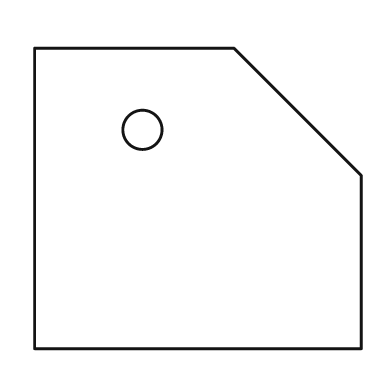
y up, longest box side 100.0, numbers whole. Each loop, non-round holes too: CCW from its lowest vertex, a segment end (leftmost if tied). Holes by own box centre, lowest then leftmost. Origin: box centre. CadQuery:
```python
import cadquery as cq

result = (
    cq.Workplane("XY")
    .moveTo(-50.0, -46.0)
    .lineTo(50.0, -46.0)
    .lineTo(50.0, 7.0)
    .lineTo(11.0, 46.0)
    .lineTo(-50.0, 46.0)
    .close()
    .moveTo(-17.0, 21.0)
    .circle(6.0)
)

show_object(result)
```